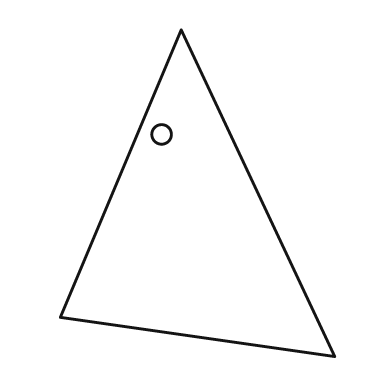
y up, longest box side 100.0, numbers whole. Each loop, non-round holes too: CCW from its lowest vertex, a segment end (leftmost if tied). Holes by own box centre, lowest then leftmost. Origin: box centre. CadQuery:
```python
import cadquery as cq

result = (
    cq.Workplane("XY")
    .moveTo(42.0, -50.0)
    .lineTo(-5.0, 50.0)
    .lineTo(-42.0, -38.0)
    .close()
    .moveTo(-11.0, 18.0)
    .circle(3.0)
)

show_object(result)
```